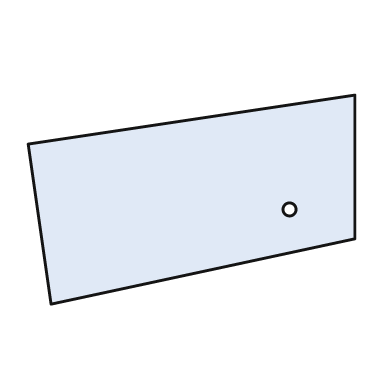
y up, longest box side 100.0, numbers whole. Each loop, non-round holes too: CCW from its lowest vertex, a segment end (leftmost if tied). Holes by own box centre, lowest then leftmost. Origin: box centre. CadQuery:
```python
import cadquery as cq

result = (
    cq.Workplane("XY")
    .moveTo(-43.0, -32.0)
    .lineTo(50.0, -12.0)
    .lineTo(50.0, 32.0)
    .lineTo(-50.0, 17.0)
    .close()
    .moveTo(30.0, -3.0)
    .circle(2.0)
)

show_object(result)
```